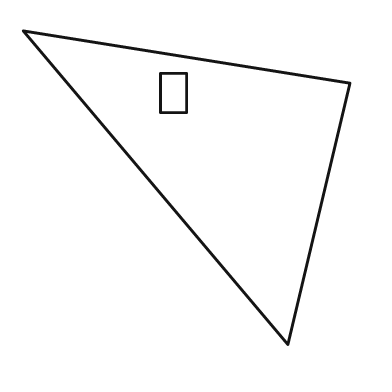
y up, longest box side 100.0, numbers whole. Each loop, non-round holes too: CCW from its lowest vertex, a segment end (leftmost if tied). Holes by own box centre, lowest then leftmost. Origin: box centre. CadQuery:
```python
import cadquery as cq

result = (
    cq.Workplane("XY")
    .moveTo(31.0, -48.0)
    .lineTo(50.0, 32.0)
    .lineTo(-50.0, 48.0)
    .close()
    .moveTo(-8.0, 23.0)
    .lineTo(0.0, 23.0)
    .lineTo(0.0, 35.0)
    .lineTo(-8.0, 35.0)
    .close()
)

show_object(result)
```